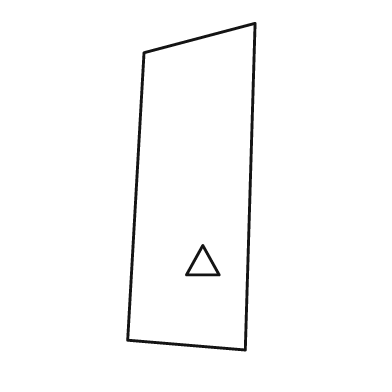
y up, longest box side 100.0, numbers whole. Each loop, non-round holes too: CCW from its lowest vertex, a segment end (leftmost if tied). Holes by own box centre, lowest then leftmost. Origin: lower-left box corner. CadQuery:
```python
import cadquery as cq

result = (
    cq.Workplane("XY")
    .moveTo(36.0, 0.0)
    .lineTo(39.0, 100.0)
    .lineTo(5.0, 91.0)
    .lineTo(0.0, 3.0)
    .close()
    .moveTo(18.0, 23.0)
    .lineTo(28.0, 23.0)
    .lineTo(23.0, 32.0)
    .close()
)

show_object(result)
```